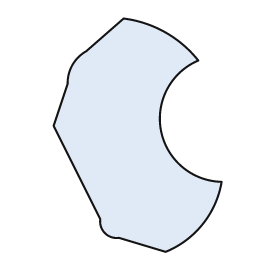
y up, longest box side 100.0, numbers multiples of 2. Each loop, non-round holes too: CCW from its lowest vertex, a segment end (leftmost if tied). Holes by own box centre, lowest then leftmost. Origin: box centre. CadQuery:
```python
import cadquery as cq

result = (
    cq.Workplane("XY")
    .moveTo(12.0, -50.0)
    .threePointArc((28.0, -38.0), (36.0, -20.0))
    .threePointArc((10.0, 2.0), (26.0, 32.0))
    .threePointArc((12.0, 44.0), (-6.0, 50.0))
    .lineTo(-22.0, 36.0)
    .threePointArc((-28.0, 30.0), (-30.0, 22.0))
    .lineTo(-36.0, 4.0)
    .lineTo(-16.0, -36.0)
    .threePointArc((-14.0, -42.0), (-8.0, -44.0))
    .close()
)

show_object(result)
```